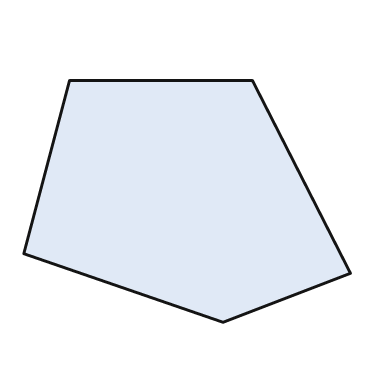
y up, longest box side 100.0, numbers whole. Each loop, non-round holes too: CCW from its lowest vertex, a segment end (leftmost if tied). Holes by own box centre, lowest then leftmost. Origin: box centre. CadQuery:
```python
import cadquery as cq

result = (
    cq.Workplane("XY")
    .moveTo(11.0, -37.0)
    .lineTo(50.0, -22.0)
    .lineTo(20.0, 37.0)
    .lineTo(-36.0, 37.0)
    .lineTo(-50.0, -16.0)
    .close()
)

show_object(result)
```